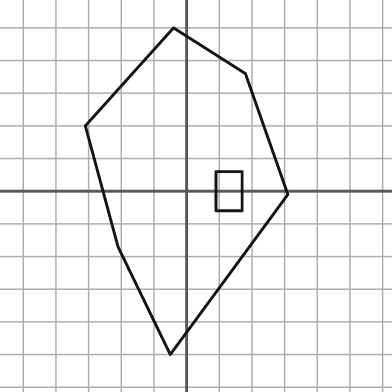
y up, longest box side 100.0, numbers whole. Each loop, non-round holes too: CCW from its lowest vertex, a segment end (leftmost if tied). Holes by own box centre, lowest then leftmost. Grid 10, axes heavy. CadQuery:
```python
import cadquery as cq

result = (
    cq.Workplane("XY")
    .moveTo(-5.0, -50.0)
    .lineTo(31.0, -1.0)
    .lineTo(18.0, 36.0)
    .lineTo(-4.0, 50.0)
    .lineTo(-31.0, 20.0)
    .lineTo(-21.0, -17.0)
    .close()
    .moveTo(9.0, -6.0)
    .lineTo(17.0, -6.0)
    .lineTo(17.0, 6.0)
    .lineTo(9.0, 6.0)
    .close()
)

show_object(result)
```